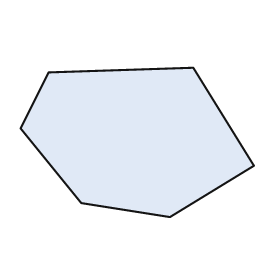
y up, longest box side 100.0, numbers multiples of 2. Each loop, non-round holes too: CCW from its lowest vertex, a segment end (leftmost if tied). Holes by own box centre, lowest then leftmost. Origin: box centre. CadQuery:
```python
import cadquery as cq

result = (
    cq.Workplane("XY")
    .moveTo(14.0, -32.0)
    .lineTo(50.0, -10.0)
    .lineTo(24.0, 32.0)
    .lineTo(-38.0, 30.0)
    .lineTo(-50.0, 6.0)
    .lineTo(-24.0, -26.0)
    .close()
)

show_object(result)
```